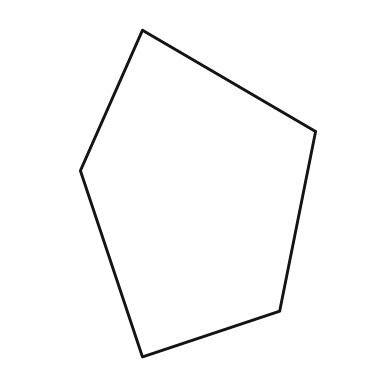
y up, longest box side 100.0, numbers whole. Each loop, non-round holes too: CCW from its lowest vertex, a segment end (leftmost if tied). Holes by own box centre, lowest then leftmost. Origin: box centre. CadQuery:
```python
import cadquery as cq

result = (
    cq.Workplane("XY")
    .moveTo(-17.0, -50.0)
    .lineTo(25.0, -36.0)
    .lineTo(36.0, 19.0)
    .lineTo(-17.0, 50.0)
    .lineTo(-36.0, 7.0)
    .close()
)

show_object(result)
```